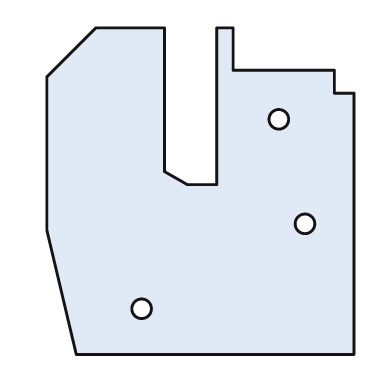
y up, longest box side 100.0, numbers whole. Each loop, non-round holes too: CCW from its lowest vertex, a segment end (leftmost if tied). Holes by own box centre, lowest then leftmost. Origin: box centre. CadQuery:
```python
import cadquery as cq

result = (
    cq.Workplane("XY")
    .moveTo(-38.0, -50.0)
    .lineTo(47.0, -50.0)
    .lineTo(47.0, 30.0)
    .lineTo(41.0, 30.0)
    .lineTo(41.0, 37.0)
    .lineTo(10.0, 37.0)
    .lineTo(10.0, 50.0)
    .lineTo(5.0, 50.0)
    .lineTo(5.0, 2.0)
    .lineTo(-4.0, 2.0)
    .lineTo(-11.0, 6.0)
    .lineTo(-11.0, 50.0)
    .lineTo(-32.0, 50.0)
    .lineTo(-47.0, 35.0)
    .lineTo(-47.0, -12.0)
    .close()
    .moveTo(-18.0, -36.0)
    .circle(3.0)
    .moveTo(32.0, -10.0)
    .circle(3.0)
    .moveTo(24.0, 22.0)
    .circle(3.0)
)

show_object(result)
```